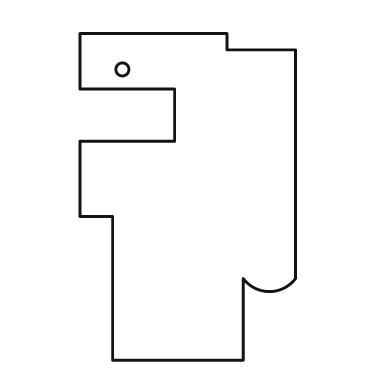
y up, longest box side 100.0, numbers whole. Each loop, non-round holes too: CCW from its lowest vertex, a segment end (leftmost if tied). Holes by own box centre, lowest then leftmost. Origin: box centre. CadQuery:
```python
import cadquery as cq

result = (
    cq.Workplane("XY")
    .moveTo(-23.0, -50.0)
    .lineTo(17.0, -50.0)
    .lineTo(17.0, -25.0)
    .threePointArc((25.0, -29.0), (33.0, -25.0))
    .lineTo(33.0, 45.0)
    .lineTo(12.0, 45.0)
    .lineTo(12.0, 50.0)
    .lineTo(-33.0, 50.0)
    .lineTo(-33.0, 33.0)
    .lineTo(-4.0, 33.0)
    .lineTo(-4.0, 17.0)
    .lineTo(-33.0, 17.0)
    .lineTo(-33.0, -6.0)
    .lineTo(-23.0, -6.0)
    .close()
    .moveTo(-20.0, 39.0)
    .circle(2.0)
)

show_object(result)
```